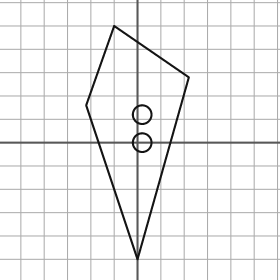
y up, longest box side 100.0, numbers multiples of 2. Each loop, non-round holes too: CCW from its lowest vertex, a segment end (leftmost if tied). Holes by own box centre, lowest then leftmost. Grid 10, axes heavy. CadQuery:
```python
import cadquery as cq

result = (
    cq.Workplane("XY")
    .moveTo(0.0, -50.0)
    .lineTo(22.0, 28.0)
    .lineTo(-10.0, 50.0)
    .lineTo(-22.0, 16.0)
    .close()
    .moveTo(2.0, 0.0)
    .circle(4.0)
    .moveTo(2.0, 12.0)
    .circle(4.0)
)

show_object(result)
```